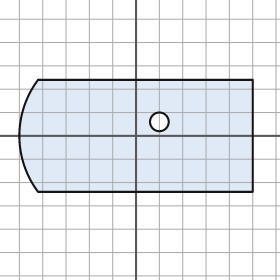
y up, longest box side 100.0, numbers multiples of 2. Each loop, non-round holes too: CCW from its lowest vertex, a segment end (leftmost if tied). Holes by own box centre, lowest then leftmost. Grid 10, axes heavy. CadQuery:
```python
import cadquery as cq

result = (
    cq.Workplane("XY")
    .moveTo(-42.0, -24.0)
    .lineTo(50.0, -24.0)
    .lineTo(50.0, 24.0)
    .lineTo(-42.0, 24.0)
    .threePointArc((-50.0, 0.0), (-42.0, -24.0))
    .close()
    .moveTo(10.0, 6.0)
    .circle(4.0)
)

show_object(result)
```